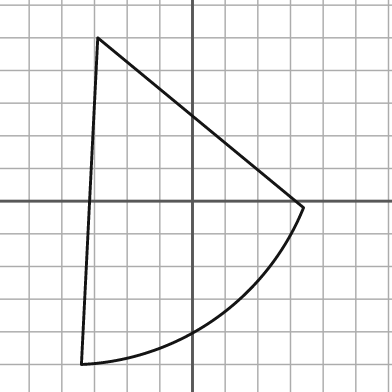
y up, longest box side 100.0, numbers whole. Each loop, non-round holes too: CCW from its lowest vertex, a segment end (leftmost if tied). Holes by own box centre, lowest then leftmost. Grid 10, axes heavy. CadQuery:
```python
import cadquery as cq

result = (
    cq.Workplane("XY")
    .moveTo(-34.0, -50.0)
    .threePointArc((7.0, -36.0), (34.0, -2.0))
    .lineTo(-29.0, 50.0)
    .close()
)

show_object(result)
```